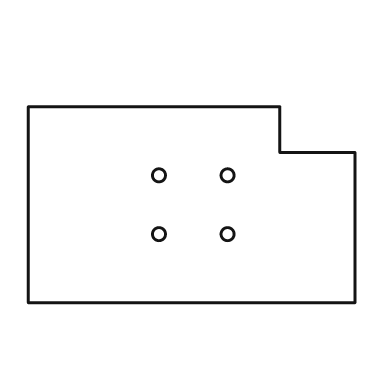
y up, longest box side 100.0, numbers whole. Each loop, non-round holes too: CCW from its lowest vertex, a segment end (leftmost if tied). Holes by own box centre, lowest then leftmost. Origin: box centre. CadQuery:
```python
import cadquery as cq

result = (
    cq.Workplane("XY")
    .moveTo(-50.0, -30.0)
    .lineTo(50.0, -30.0)
    .lineTo(50.0, 16.0)
    .lineTo(27.0, 16.0)
    .lineTo(27.0, 30.0)
    .lineTo(-50.0, 30.0)
    .close()
    .moveTo(-10.0, -9.0)
    .circle(2.0)
    .moveTo(11.0, -9.0)
    .circle(2.0)
    .moveTo(-10.0, 9.0)
    .circle(2.0)
    .moveTo(11.0, 9.0)
    .circle(2.0)
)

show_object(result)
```